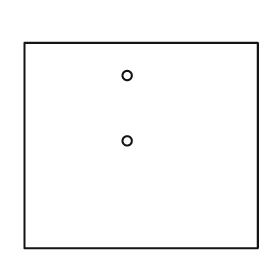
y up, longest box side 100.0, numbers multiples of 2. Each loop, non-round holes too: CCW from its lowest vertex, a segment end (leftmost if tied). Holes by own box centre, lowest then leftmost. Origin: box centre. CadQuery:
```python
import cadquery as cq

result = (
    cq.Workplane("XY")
    .moveTo(-50.0, -44.0)
    .lineTo(50.0, -44.0)
    .lineTo(50.0, 44.0)
    .lineTo(-50.0, 44.0)
    .close()
    .moveTo(-6.0, 2.0)
    .circle(2.0)
    .moveTo(-6.0, 30.0)
    .circle(2.0)
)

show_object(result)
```